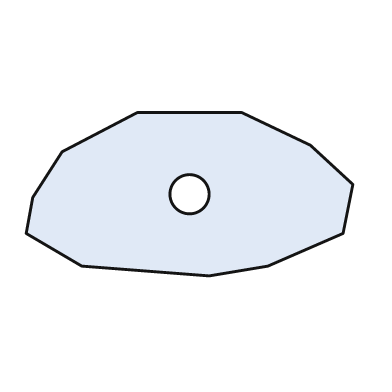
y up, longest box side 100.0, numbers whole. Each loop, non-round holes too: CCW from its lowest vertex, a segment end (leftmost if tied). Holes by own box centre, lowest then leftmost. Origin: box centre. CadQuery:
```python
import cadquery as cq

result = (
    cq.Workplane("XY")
    .moveTo(6.0, -25.0)
    .lineTo(24.0, -22.0)
    .lineTo(47.0, -12.0)
    .lineTo(50.0, 3.0)
    .lineTo(37.0, 15.0)
    .lineTo(16.0, 25.0)
    .lineTo(-16.0, 25.0)
    .lineTo(-39.0, 13.0)
    .lineTo(-48.0, -1.0)
    .lineTo(-50.0, -12.0)
    .lineTo(-33.0, -22.0)
    .close()
    .moveTo(0.0, 0.0)
    .circle(6.0)
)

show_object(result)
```